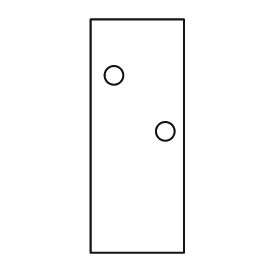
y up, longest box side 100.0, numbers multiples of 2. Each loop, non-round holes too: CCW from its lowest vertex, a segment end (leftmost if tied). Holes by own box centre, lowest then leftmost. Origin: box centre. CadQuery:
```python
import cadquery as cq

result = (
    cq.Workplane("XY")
    .moveTo(-20.0, -50.0)
    .lineTo(20.0, -50.0)
    .lineTo(20.0, 50.0)
    .lineTo(-20.0, 50.0)
    .close()
    .moveTo(12.0, 2.0)
    .circle(4.0)
    .moveTo(-10.0, 26.0)
    .circle(4.0)
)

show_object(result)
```